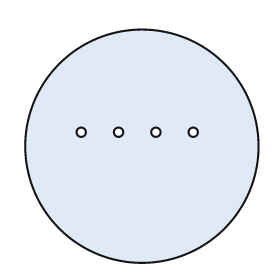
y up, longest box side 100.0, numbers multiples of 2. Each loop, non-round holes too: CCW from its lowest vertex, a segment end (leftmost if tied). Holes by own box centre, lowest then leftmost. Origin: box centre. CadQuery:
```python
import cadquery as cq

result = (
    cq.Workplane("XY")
    .moveTo(0.0, 0.0)
    .circle(50.0)
    .moveTo(-26.0, 6.0)
    .circle(2.0)
    .moveTo(-10.0, 6.0)
    .circle(2.0)
    .moveTo(6.0, 6.0)
    .circle(2.0)
    .moveTo(22.0, 6.0)
    .circle(2.0)
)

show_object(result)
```